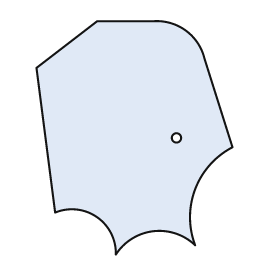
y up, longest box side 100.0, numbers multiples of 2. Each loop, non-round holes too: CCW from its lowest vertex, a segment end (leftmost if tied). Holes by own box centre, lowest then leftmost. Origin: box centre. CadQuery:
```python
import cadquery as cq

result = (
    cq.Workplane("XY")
    .moveTo(-8.0, -50.0)
    .threePointArc((8.0, -40.0), (26.0, -46.0))
    .threePointArc((26.0, -22.0), (42.0, -4.0))
    .lineTo(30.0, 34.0)
    .threePointArc((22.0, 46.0), (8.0, 50.0))
    .lineTo(-16.0, 50.0)
    .lineTo(-42.0, 30.0)
    .lineTo(-34.0, -32.0)
    .threePointArc((-16.0, -34.0), (-8.0, -50.0))
    .close()
    .moveTo(18.0, 0.0)
    .circle(2.0)
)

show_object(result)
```